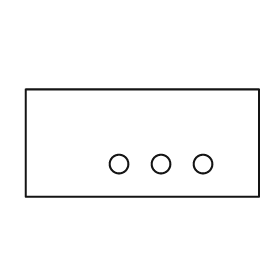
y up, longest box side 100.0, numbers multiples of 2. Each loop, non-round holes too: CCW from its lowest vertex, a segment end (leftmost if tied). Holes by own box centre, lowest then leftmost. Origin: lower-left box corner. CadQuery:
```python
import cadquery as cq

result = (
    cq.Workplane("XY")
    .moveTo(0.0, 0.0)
    .lineTo(100.0, 0.0)
    .lineTo(100.0, 46.0)
    .lineTo(0.0, 46.0)
    .close()
    .moveTo(40.0, 14.0)
    .circle(4.0)
    .moveTo(58.0, 14.0)
    .circle(4.0)
    .moveTo(76.0, 14.0)
    .circle(4.0)
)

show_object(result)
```